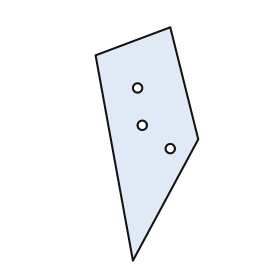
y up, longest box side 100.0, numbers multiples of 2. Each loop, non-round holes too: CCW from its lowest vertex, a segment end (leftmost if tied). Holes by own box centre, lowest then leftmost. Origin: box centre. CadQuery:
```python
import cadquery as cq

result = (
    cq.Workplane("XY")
    .moveTo(-6.0, -50.0)
    .lineTo(22.0, 2.0)
    .lineTo(10.0, 50.0)
    .lineTo(-22.0, 38.0)
    .close()
    .moveTo(10.0, -2.0)
    .circle(2.0)
    .moveTo(-2.0, 8.0)
    .circle(2.0)
    .moveTo(-4.0, 24.0)
    .circle(2.0)
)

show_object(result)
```